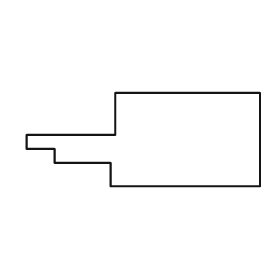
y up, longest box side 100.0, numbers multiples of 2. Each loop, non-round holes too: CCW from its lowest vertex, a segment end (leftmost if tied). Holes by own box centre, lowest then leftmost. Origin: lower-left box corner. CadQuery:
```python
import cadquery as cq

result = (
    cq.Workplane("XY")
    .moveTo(36.0, 0.0)
    .lineTo(100.0, 0.0)
    .lineTo(100.0, 40.0)
    .lineTo(38.0, 40.0)
    .lineTo(38.0, 22.0)
    .lineTo(0.0, 22.0)
    .lineTo(0.0, 16.0)
    .lineTo(12.0, 16.0)
    .lineTo(12.0, 10.0)
    .lineTo(36.0, 10.0)
    .close()
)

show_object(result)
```